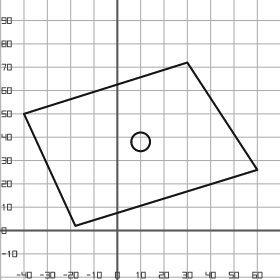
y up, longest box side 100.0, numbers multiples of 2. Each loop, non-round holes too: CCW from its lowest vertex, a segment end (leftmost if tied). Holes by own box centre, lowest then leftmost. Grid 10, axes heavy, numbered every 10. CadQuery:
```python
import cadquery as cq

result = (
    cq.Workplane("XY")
    .moveTo(-18.0, 2.0)
    .lineTo(60.0, 26.0)
    .lineTo(30.0, 72.0)
    .lineTo(-40.0, 50.0)
    .close()
    .moveTo(10.0, 38.0)
    .circle(4.0)
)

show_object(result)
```